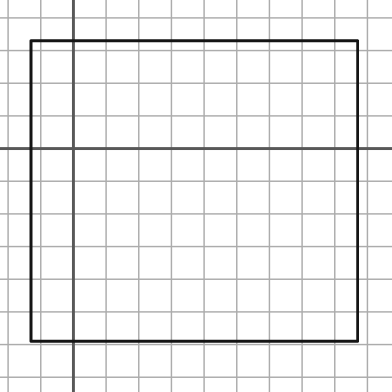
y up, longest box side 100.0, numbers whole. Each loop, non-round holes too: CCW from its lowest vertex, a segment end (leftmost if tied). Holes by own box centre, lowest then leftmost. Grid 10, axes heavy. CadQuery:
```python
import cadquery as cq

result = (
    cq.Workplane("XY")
    .moveTo(-13.0, -59.0)
    .lineTo(87.0, -59.0)
    .lineTo(87.0, 33.0)
    .lineTo(-13.0, 33.0)
    .close()
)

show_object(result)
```